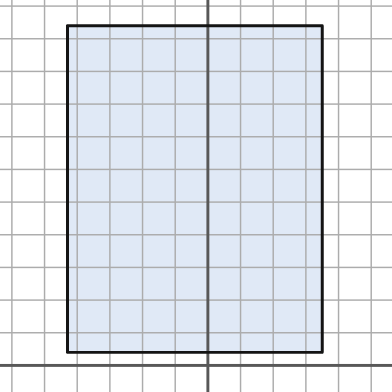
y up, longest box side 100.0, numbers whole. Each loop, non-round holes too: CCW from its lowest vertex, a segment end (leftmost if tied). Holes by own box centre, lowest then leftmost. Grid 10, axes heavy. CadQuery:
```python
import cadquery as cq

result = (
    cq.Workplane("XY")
    .moveTo(-43.0, 4.0)
    .lineTo(35.0, 4.0)
    .lineTo(35.0, 104.0)
    .lineTo(-43.0, 104.0)
    .close()
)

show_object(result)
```